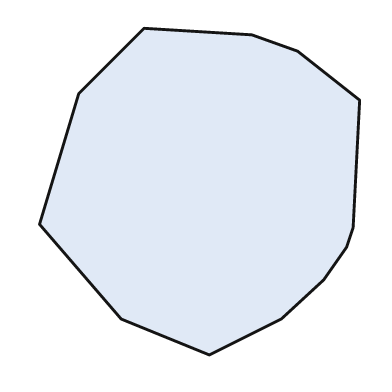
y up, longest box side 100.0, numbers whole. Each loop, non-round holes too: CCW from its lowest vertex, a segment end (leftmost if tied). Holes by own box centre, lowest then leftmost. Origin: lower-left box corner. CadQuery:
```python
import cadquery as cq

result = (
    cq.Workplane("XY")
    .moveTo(52.0, 0.0)
    .lineTo(74.0, 11.0)
    .lineTo(87.0, 23.0)
    .lineTo(94.0, 33.0)
    .lineTo(96.0, 39.0)
    .lineTo(98.0, 78.0)
    .lineTo(79.0, 93.0)
    .lineTo(65.0, 98.0)
    .lineTo(32.0, 100.0)
    .lineTo(12.0, 80.0)
    .lineTo(0.0, 40.0)
    .lineTo(25.0, 11.0)
    .close()
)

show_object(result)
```